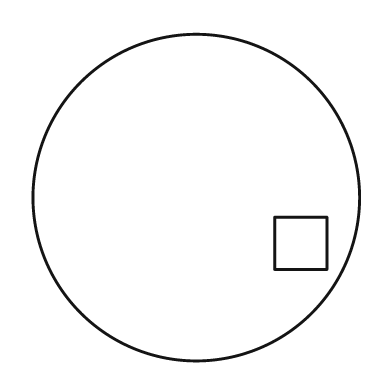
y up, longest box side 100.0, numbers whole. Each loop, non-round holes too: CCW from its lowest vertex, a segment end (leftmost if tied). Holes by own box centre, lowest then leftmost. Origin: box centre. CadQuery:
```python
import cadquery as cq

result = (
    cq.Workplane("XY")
    .moveTo(0.0, 0.0)
    .circle(50.0)
    .moveTo(24.0, -22.0)
    .lineTo(40.0, -22.0)
    .lineTo(40.0, -6.0)
    .lineTo(24.0, -6.0)
    .close()
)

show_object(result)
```